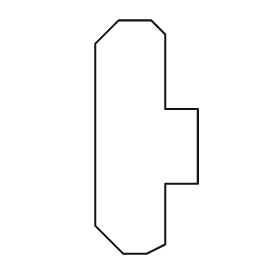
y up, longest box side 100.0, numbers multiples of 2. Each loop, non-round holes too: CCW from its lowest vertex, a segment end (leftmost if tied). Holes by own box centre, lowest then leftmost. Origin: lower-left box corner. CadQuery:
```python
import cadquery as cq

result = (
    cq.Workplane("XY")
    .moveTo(12.0, 0.0)
    .lineTo(22.0, 0.0)
    .lineTo(30.0, 4.0)
    .lineTo(30.0, 30.0)
    .lineTo(44.0, 30.0)
    .lineTo(44.0, 62.0)
    .lineTo(30.0, 62.0)
    .lineTo(30.0, 94.0)
    .lineTo(24.0, 100.0)
    .lineTo(10.0, 100.0)
    .lineTo(0.0, 90.0)
    .lineTo(0.0, 12.0)
    .close()
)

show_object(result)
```